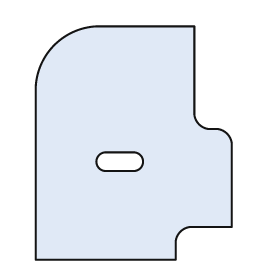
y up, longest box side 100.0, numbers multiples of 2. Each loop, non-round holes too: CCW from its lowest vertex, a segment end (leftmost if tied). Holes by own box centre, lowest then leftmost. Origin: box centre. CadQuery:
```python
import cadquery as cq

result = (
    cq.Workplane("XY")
    .moveTo(-42.0, -50.0)
    .lineTo(18.0, -50.0)
    .lineTo(18.0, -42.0)
    .threePointArc((20.0, -38.0), (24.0, -36.0))
    .lineTo(42.0, -36.0)
    .lineTo(42.0, 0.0)
    .threePointArc((40.0, 4.0), (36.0, 6.0))
    .lineTo(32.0, 6.0)
    .threePointArc((28.0, 8.0), (26.0, 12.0))
    .lineTo(26.0, 50.0)
    .lineTo(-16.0, 50.0)
    .threePointArc((-34.0, 42.0), (-42.0, 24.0))
    .close()
    .moveTo(-12.0, -12.0)
    .lineTo(0.0, -12.0)
    .threePointArc((4.0, -8.0), (0.0, -4.0))
    .lineTo(-12.0, -4.0)
    .threePointArc((-16.0, -8.0), (-12.0, -12.0))
    .close()
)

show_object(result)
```